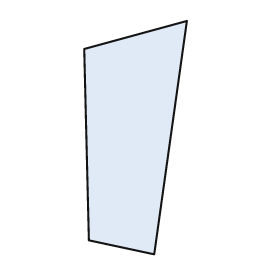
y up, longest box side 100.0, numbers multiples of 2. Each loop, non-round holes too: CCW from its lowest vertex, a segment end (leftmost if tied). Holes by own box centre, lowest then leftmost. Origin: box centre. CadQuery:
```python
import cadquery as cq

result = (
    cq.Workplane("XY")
    .moveTo(8.0, -50.0)
    .lineTo(22.0, 50.0)
    .lineTo(-22.0, 38.0)
    .lineTo(-20.0, -44.0)
    .close()
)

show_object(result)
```